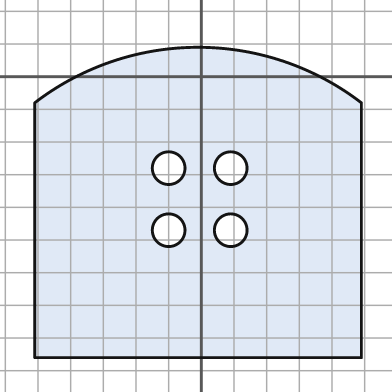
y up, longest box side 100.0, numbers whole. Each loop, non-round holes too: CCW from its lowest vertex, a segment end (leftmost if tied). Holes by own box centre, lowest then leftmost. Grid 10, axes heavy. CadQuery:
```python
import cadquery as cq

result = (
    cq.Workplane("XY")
    .moveTo(-51.0, -86.0)
    .lineTo(49.0, -86.0)
    .lineTo(49.0, -8.0)
    .threePointArc((-1.0, 9.0), (-51.0, -8.0))
    .close()
    .moveTo(-10.0, -47.0)
    .circle(5.0)
    .moveTo(9.0, -47.0)
    .circle(5.0)
    .moveTo(-10.0, -28.0)
    .circle(5.0)
    .moveTo(9.0, -28.0)
    .circle(5.0)
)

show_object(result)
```